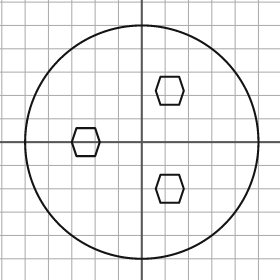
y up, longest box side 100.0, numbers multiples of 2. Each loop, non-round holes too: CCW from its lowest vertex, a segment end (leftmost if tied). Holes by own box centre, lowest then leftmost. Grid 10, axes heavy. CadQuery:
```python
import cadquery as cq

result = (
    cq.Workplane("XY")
    .moveTo(0.0, 0.0)
    .circle(50.0)
    .moveTo(8.0, -26.0)
    .lineTo(16.0, -26.0)
    .lineTo(18.0, -20.0)
    .lineTo(16.0, -14.0)
    .lineTo(8.0, -14.0)
    .lineTo(6.0, -20.0)
    .close()
    .moveTo(-28.0, -6.0)
    .lineTo(-20.0, -6.0)
    .lineTo(-18.0, 0.0)
    .lineTo(-20.0, 6.0)
    .lineTo(-28.0, 6.0)
    .lineTo(-30.0, 0.0)
    .close()
    .moveTo(8.0, 16.0)
    .lineTo(16.0, 16.0)
    .lineTo(18.0, 22.0)
    .lineTo(16.0, 28.0)
    .lineTo(8.0, 28.0)
    .lineTo(6.0, 22.0)
    .close()
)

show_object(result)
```